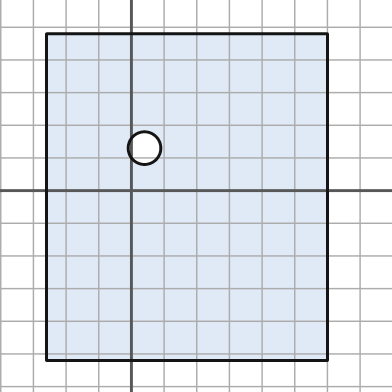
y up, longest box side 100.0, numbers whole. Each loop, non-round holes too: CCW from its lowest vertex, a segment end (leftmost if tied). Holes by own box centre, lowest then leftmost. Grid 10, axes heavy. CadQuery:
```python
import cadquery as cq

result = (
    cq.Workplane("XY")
    .moveTo(-26.0, -52.0)
    .lineTo(60.0, -52.0)
    .lineTo(60.0, 48.0)
    .lineTo(-26.0, 48.0)
    .close()
    .moveTo(4.0, 13.0)
    .circle(5.0)
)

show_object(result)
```